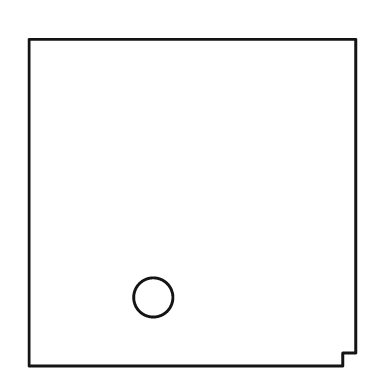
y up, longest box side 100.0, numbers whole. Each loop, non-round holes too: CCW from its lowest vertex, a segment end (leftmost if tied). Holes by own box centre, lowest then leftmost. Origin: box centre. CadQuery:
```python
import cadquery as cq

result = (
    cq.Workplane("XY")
    .moveTo(-50.0, -50.0)
    .lineTo(46.0, -50.0)
    .lineTo(46.0, -46.0)
    .lineTo(50.0, -46.0)
    .lineTo(50.0, 50.0)
    .lineTo(-50.0, 50.0)
    .close()
    .moveTo(-12.0, -29.0)
    .circle(6.0)
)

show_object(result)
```